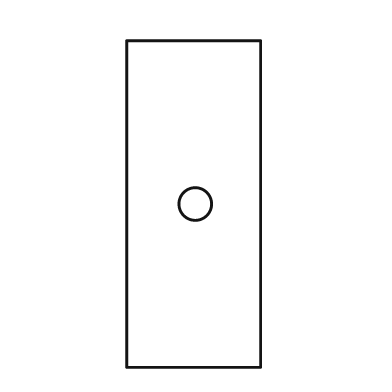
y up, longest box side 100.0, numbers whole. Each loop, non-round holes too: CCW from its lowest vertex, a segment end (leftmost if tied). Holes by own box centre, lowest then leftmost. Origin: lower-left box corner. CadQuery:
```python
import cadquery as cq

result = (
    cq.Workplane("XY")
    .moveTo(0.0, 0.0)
    .lineTo(41.0, 0.0)
    .lineTo(41.0, 100.0)
    .lineTo(0.0, 100.0)
    .close()
    .moveTo(21.0, 50.0)
    .circle(5.0)
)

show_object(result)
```